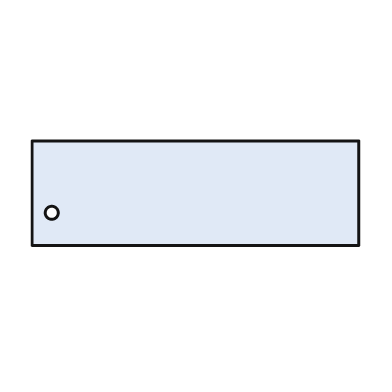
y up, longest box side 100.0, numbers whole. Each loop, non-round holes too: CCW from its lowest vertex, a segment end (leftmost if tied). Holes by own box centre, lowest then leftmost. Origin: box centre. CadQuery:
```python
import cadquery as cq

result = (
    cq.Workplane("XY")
    .moveTo(-50.0, -16.0)
    .lineTo(50.0, -16.0)
    .lineTo(50.0, 16.0)
    .lineTo(-50.0, 16.0)
    .close()
    .moveTo(-44.0, -6.0)
    .circle(2.0)
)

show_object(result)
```